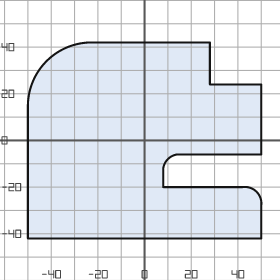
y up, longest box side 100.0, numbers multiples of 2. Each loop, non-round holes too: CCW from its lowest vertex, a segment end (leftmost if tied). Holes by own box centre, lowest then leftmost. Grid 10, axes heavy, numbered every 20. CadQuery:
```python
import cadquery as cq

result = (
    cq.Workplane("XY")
    .moveTo(-50.0, -42.0)
    .lineTo(50.0, -42.0)
    .lineTo(50.0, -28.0)
    .threePointArc((48.0, -22.0), (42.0, -20.0))
    .lineTo(8.0, -20.0)
    .lineTo(8.0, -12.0)
    .threePointArc((10.0, -8.0), (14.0, -6.0))
    .lineTo(50.0, -6.0)
    .lineTo(50.0, 24.0)
    .lineTo(28.0, 24.0)
    .lineTo(28.0, 42.0)
    .lineTo(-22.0, 42.0)
    .threePointArc((-42.0, 34.0), (-50.0, 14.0))
    .close()
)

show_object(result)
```